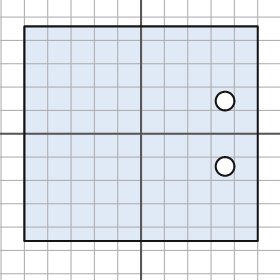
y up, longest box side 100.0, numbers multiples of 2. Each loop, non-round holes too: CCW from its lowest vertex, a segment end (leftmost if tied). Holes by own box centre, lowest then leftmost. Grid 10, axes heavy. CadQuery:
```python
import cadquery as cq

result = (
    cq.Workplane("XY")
    .moveTo(-50.0, -46.0)
    .lineTo(50.0, -46.0)
    .lineTo(50.0, 46.0)
    .lineTo(-50.0, 46.0)
    .close()
    .moveTo(36.0, -14.0)
    .circle(4.0)
    .moveTo(36.0, 14.0)
    .circle(4.0)
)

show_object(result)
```